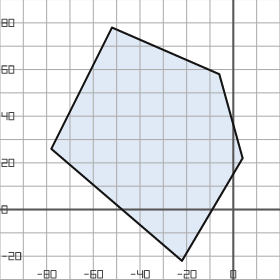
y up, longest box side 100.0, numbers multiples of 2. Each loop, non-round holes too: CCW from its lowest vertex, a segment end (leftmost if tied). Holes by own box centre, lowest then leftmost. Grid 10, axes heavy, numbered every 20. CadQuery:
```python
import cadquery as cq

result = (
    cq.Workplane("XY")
    .moveTo(-22.0, -22.0)
    .lineTo(4.0, 22.0)
    .lineTo(-6.0, 58.0)
    .lineTo(-52.0, 78.0)
    .lineTo(-78.0, 26.0)
    .close()
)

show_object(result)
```